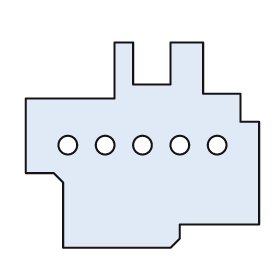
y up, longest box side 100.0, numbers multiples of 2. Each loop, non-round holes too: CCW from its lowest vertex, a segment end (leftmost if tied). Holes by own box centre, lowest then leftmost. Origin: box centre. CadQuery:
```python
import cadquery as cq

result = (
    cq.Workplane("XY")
    .moveTo(-34.0, -44.0)
    .lineTo(12.0, -44.0)
    .lineTo(16.0, -40.0)
    .lineTo(16.0, -34.0)
    .lineTo(50.0, -34.0)
    .lineTo(50.0, 10.0)
    .lineTo(42.0, 10.0)
    .lineTo(42.0, 22.0)
    .lineTo(26.0, 22.0)
    .lineTo(26.0, 44.0)
    .lineTo(12.0, 44.0)
    .lineTo(12.0, 26.0)
    .lineTo(-4.0, 26.0)
    .lineTo(-4.0, 44.0)
    .lineTo(-12.0, 44.0)
    .lineTo(-12.0, 20.0)
    .lineTo(-50.0, 20.0)
    .lineTo(-50.0, -12.0)
    .lineTo(-38.0, -12.0)
    .lineTo(-34.0, -16.0)
    .close()
    .moveTo(-32.0, 0.0)
    .circle(4.0)
    .moveTo(-16.0, 0.0)
    .circle(4.0)
    .moveTo(0.0, 0.0)
    .circle(4.0)
    .moveTo(16.0, 0.0)
    .circle(4.0)
    .moveTo(32.0, 0.0)
    .circle(4.0)
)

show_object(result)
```